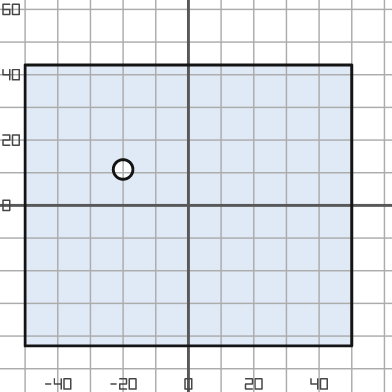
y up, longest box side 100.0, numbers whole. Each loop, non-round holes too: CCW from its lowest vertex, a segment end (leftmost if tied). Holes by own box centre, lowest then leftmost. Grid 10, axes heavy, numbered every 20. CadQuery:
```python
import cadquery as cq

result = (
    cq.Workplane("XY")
    .moveTo(-50.0, -43.0)
    .lineTo(50.0, -43.0)
    .lineTo(50.0, 43.0)
    .lineTo(-50.0, 43.0)
    .close()
    .moveTo(-20.0, 11.0)
    .circle(3.0)
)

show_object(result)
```